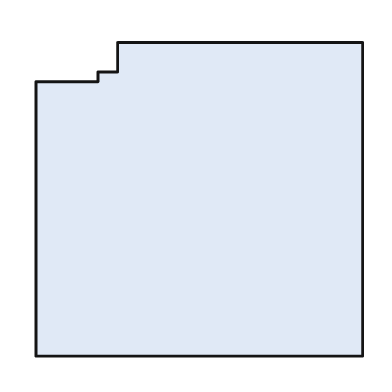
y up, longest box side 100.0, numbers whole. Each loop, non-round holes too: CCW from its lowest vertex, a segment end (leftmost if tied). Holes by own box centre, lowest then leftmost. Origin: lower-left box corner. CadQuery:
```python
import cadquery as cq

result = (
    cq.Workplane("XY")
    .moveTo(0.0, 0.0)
    .lineTo(100.0, 0.0)
    .lineTo(100.0, 96.0)
    .lineTo(25.0, 96.0)
    .lineTo(25.0, 87.0)
    .lineTo(19.0, 87.0)
    .lineTo(19.0, 84.0)
    .lineTo(0.0, 84.0)
    .close()
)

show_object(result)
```